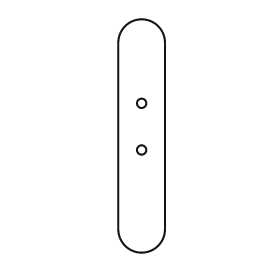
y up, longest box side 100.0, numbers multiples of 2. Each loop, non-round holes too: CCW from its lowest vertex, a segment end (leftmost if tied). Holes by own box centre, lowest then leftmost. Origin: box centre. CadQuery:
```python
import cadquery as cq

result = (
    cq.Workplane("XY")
    .moveTo(-10.0, -40.0)
    .threePointArc((0.0, -50.0), (10.0, -40.0))
    .lineTo(10.0, 40.0)
    .threePointArc((0.0, 50.0), (-10.0, 40.0))
    .close()
    .moveTo(0.0, -6.0)
    .circle(2.0)
    .moveTo(0.0, 14.0)
    .circle(2.0)
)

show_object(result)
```